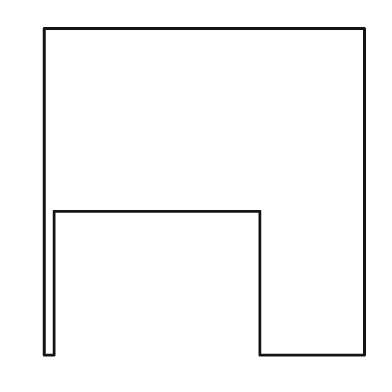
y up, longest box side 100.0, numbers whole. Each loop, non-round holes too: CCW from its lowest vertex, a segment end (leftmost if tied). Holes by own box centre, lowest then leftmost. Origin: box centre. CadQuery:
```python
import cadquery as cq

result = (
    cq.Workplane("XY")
    .moveTo(-49.0, -50.0)
    .lineTo(-46.0, -50.0)
    .lineTo(-46.0, -6.0)
    .lineTo(17.0, -6.0)
    .lineTo(17.0, -50.0)
    .lineTo(49.0, -50.0)
    .lineTo(49.0, 50.0)
    .lineTo(-49.0, 50.0)
    .close()
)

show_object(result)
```